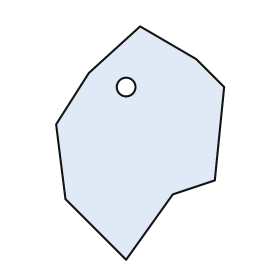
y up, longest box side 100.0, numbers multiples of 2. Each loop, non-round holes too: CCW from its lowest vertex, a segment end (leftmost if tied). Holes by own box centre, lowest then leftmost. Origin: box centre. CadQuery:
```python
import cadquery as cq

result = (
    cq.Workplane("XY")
    .moveTo(-6.0, -50.0)
    .lineTo(14.0, -22.0)
    .lineTo(32.0, -16.0)
    .lineTo(36.0, 24.0)
    .lineTo(24.0, 36.0)
    .lineTo(0.0, 50.0)
    .lineTo(-22.0, 30.0)
    .lineTo(-36.0, 8.0)
    .lineTo(-32.0, -24.0)
    .close()
    .moveTo(-6.0, 24.0)
    .circle(4.0)
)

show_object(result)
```